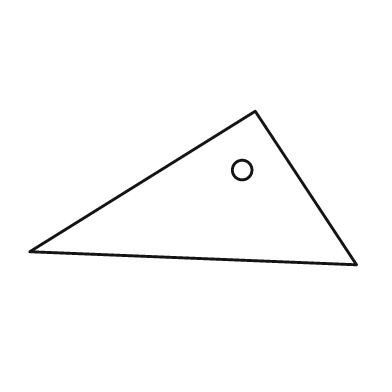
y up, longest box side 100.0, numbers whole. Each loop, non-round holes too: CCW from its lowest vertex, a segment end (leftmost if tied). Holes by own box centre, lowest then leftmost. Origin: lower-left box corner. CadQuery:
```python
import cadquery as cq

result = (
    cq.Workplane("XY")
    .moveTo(100.0, 0.0)
    .lineTo(69.0, 47.0)
    .lineTo(0.0, 4.0)
    .close()
    .moveTo(65.0, 29.0)
    .circle(3.0)
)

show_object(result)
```